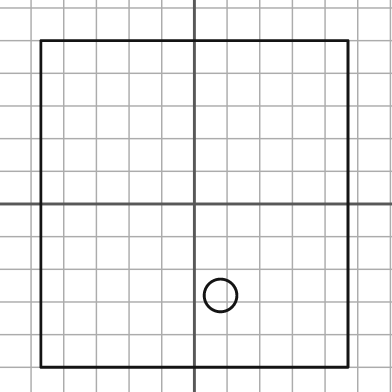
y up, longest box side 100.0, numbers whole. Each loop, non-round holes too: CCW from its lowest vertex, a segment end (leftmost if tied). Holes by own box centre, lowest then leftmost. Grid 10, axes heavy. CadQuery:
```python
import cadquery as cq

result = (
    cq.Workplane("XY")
    .moveTo(-47.0, -50.0)
    .lineTo(47.0, -50.0)
    .lineTo(47.0, 50.0)
    .lineTo(-47.0, 50.0)
    .close()
    .moveTo(8.0, -28.0)
    .circle(5.0)
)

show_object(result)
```